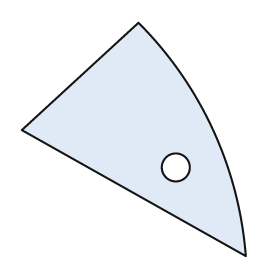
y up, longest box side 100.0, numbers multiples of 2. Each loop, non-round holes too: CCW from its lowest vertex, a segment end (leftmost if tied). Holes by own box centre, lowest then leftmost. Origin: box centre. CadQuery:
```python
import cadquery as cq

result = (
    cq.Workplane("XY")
    .moveTo(48.0, -50.0)
    .threePointArc((34.0, 4.0), (2.0, 50.0))
    .lineTo(-48.0, 4.0)
    .close()
    .moveTo(18.0, -12.0)
    .circle(6.0)
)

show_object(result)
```